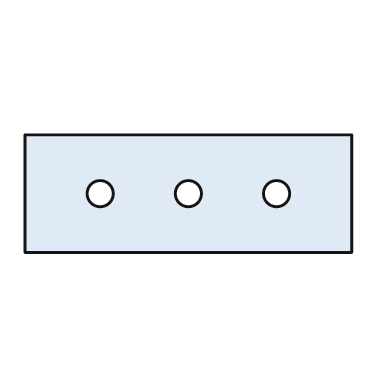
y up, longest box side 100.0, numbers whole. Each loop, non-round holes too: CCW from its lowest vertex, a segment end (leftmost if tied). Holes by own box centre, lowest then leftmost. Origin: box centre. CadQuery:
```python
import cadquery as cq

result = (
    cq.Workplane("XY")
    .moveTo(-50.0, -18.0)
    .lineTo(50.0, -18.0)
    .lineTo(50.0, 18.0)
    .lineTo(-50.0, 18.0)
    .close()
    .moveTo(-27.0, 0.0)
    .circle(4.0)
    .moveTo(0.0, 0.0)
    .circle(4.0)
    .moveTo(27.0, 0.0)
    .circle(4.0)
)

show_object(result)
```